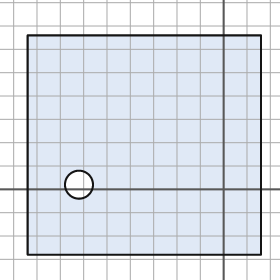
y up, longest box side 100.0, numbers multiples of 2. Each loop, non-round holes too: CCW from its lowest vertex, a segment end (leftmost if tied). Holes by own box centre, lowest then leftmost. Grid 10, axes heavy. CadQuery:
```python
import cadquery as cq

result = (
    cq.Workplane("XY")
    .moveTo(-84.0, -28.0)
    .lineTo(16.0, -28.0)
    .lineTo(16.0, 66.0)
    .lineTo(-84.0, 66.0)
    .close()
    .moveTo(-62.0, 2.0)
    .circle(6.0)
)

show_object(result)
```